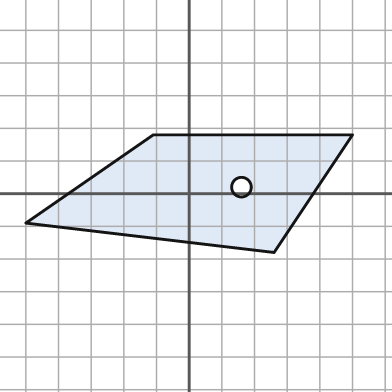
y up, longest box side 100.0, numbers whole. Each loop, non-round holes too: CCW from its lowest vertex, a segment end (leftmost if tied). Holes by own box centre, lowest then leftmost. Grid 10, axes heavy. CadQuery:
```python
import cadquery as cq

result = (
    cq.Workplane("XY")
    .moveTo(26.0, -18.0)
    .lineTo(50.0, 18.0)
    .lineTo(-11.0, 18.0)
    .lineTo(-50.0, -9.0)
    .close()
    .moveTo(16.0, 2.0)
    .circle(3.0)
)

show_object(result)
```